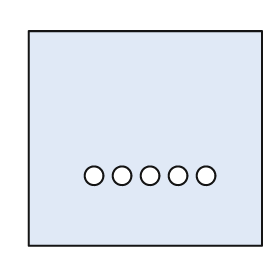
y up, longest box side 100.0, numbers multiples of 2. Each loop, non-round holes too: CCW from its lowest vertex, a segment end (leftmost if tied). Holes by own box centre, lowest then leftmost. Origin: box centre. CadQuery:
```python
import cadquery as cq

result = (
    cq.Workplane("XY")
    .moveTo(-50.0, -46.0)
    .lineTo(50.0, -46.0)
    .lineTo(50.0, 46.0)
    .lineTo(-50.0, 46.0)
    .close()
    .moveTo(-22.0, -16.0)
    .circle(4.0)
    .moveTo(-10.0, -16.0)
    .circle(4.0)
    .moveTo(2.0, -16.0)
    .circle(4.0)
    .moveTo(14.0, -16.0)
    .circle(4.0)
    .moveTo(26.0, -16.0)
    .circle(4.0)
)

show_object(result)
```